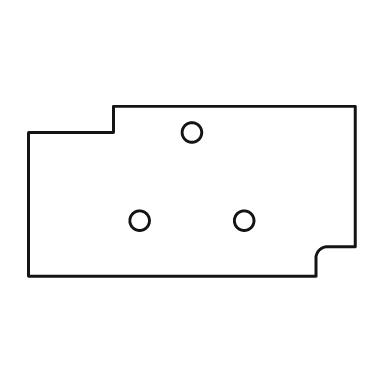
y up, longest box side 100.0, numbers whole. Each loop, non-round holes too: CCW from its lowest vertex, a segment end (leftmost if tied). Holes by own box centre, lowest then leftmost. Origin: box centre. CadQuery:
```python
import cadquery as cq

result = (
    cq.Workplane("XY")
    .moveTo(-50.0, -26.0)
    .lineTo(38.0, -26.0)
    .lineTo(38.0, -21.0)
    .threePointArc((39.0, -18.0), (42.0, -17.0))
    .lineTo(50.0, -17.0)
    .lineTo(50.0, 26.0)
    .lineTo(-24.0, 26.0)
    .lineTo(-24.0, 18.0)
    .lineTo(-50.0, 18.0)
    .close()
    .moveTo(-16.0, -9.0)
    .circle(3.0)
    .moveTo(16.0, -9.0)
    .circle(3.0)
    .moveTo(0.0, 18.0)
    .circle(3.0)
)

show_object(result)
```